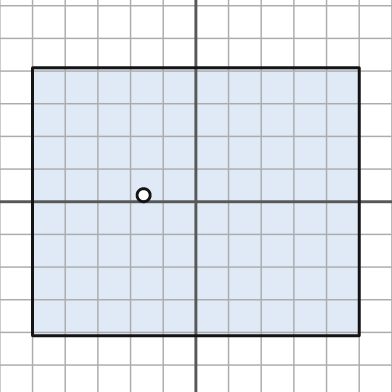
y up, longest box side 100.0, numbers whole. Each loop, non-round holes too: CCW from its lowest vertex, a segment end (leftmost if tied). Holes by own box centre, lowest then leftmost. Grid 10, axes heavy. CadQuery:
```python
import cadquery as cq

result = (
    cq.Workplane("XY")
    .moveTo(-50.0, -41.0)
    .lineTo(50.0, -41.0)
    .lineTo(50.0, 41.0)
    .lineTo(-50.0, 41.0)
    .close()
    .moveTo(-16.0, 2.0)
    .circle(2.0)
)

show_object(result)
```